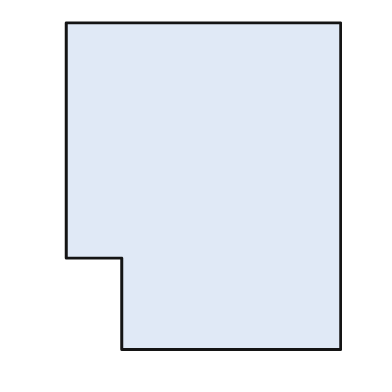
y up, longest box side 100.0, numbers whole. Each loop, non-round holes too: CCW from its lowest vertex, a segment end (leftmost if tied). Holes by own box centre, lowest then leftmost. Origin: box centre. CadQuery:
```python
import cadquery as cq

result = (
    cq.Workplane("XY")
    .moveTo(-25.0, -50.0)
    .lineTo(42.0, -50.0)
    .lineTo(42.0, 50.0)
    .lineTo(-42.0, 50.0)
    .lineTo(-42.0, -22.0)
    .lineTo(-25.0, -22.0)
    .close()
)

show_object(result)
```